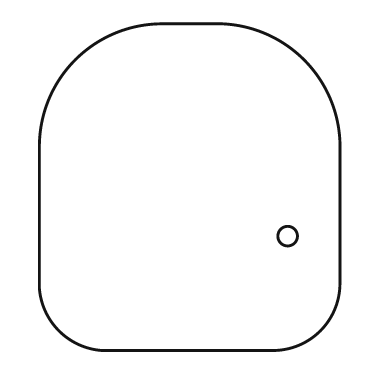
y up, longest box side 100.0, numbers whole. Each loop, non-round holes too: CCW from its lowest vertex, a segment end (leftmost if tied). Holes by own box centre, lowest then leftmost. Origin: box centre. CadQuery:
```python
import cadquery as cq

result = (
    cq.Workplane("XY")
    .moveTo(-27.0, -50.0)
    .lineTo(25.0, -50.0)
    .threePointArc((40.0, -44.0), (46.0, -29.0))
    .lineTo(46.0, 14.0)
    .threePointArc((35.0, 39.0), (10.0, 50.0))
    .lineTo(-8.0, 50.0)
    .threePointArc((-35.0, 39.0), (-46.0, 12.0))
    .lineTo(-46.0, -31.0)
    .threePointArc((-40.0, -44.0), (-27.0, -50.0))
    .close()
    .moveTo(30.0, -15.0)
    .circle(3.0)
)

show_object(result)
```